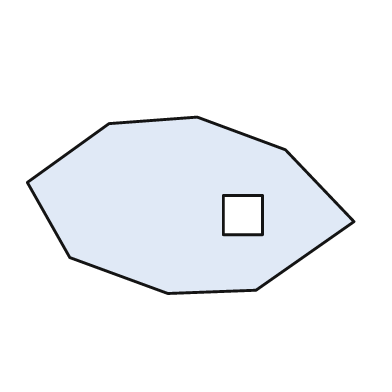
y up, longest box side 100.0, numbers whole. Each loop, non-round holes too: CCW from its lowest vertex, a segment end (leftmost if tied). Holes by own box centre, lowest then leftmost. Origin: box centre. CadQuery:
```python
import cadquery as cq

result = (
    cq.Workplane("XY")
    .moveTo(-7.0, -27.0)
    .lineTo(20.0, -26.0)
    .lineTo(50.0, -5.0)
    .lineTo(29.0, 17.0)
    .lineTo(2.0, 27.0)
    .lineTo(-25.0, 25.0)
    .lineTo(-50.0, 7.0)
    .lineTo(-37.0, -16.0)
    .close()
    .moveTo(10.0, -9.0)
    .lineTo(22.0, -9.0)
    .lineTo(22.0, 3.0)
    .lineTo(10.0, 3.0)
    .close()
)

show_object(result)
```